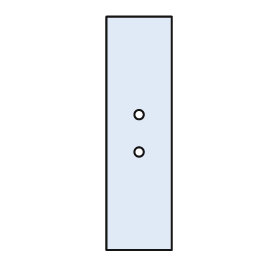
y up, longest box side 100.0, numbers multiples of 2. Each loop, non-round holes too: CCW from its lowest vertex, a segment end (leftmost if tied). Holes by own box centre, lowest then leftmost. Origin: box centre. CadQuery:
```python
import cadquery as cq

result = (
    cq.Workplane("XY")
    .moveTo(-14.0, -50.0)
    .lineTo(14.0, -50.0)
    .lineTo(14.0, 50.0)
    .lineTo(-14.0, 50.0)
    .close()
    .moveTo(0.0, -8.0)
    .circle(2.0)
    .moveTo(0.0, 8.0)
    .circle(2.0)
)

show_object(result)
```